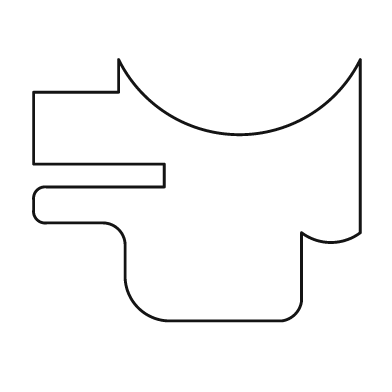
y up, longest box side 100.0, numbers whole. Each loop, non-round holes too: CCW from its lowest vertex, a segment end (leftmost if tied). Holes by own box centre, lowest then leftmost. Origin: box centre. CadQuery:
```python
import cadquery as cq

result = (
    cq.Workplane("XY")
    .moveTo(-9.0, -40.0)
    .lineTo(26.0, -40.0)
    .threePointArc((30.0, -38.0), (32.0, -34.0))
    .lineTo(32.0, -13.0)
    .threePointArc((41.0, -16.0), (50.0, -13.0))
    .lineTo(50.0, 40.0)
    .threePointArc((13.0, 17.0), (-24.0, 40.0))
    .lineTo(-24.0, 30.0)
    .lineTo(-50.0, 30.0)
    .lineTo(-50.0, 8.0)
    .lineTo(-10.0, 8.0)
    .lineTo(-10.0, 1.0)
    .lineTo(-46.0, 1.0)
    .threePointArc((-49.0, 0.0), (-50.0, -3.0))
    .lineTo(-50.0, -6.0)
    .threePointArc((-49.0, -9.0), (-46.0, -10.0))
    .lineTo(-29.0, -10.0)
    .threePointArc((-24.0, -12.0), (-22.0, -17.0))
    .lineTo(-22.0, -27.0)
    .threePointArc((-18.0, -36.0), (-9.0, -40.0))
    .close()
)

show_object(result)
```